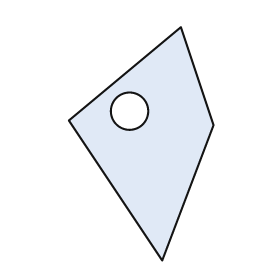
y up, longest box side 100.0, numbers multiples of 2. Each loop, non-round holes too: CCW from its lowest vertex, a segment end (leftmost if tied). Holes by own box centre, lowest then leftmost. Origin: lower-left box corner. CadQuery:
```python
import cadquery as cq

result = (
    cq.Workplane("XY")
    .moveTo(40.0, 0.0)
    .lineTo(62.0, 58.0)
    .lineTo(48.0, 100.0)
    .lineTo(0.0, 60.0)
    .close()
    .moveTo(26.0, 64.0)
    .circle(8.0)
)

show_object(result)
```